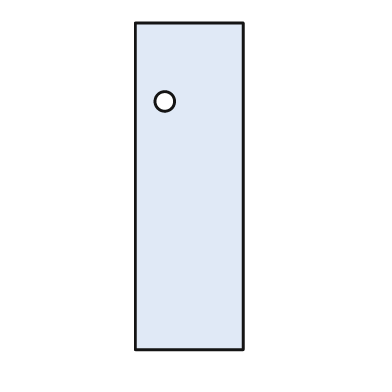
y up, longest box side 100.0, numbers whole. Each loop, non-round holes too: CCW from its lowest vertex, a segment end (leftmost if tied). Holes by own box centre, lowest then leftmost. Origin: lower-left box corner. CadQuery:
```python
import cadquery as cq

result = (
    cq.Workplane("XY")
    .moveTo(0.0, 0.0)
    .lineTo(33.0, 0.0)
    .lineTo(33.0, 100.0)
    .lineTo(0.0, 100.0)
    .close()
    .moveTo(9.0, 76.0)
    .circle(3.0)
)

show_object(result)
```